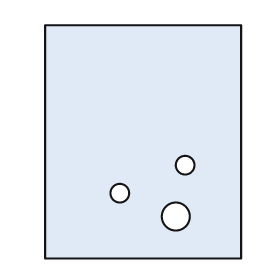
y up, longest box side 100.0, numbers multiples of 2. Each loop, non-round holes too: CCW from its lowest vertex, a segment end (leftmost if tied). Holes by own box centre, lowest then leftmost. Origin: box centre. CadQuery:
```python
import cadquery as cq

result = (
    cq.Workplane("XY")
    .moveTo(-42.0, -50.0)
    .lineTo(42.0, -50.0)
    .lineTo(42.0, 50.0)
    .lineTo(-42.0, 50.0)
    .close()
    .moveTo(14.0, -32.0)
    .circle(6.0)
    .moveTo(-10.0, -22.0)
    .circle(4.0)
    .moveTo(18.0, -10.0)
    .circle(4.0)
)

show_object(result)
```